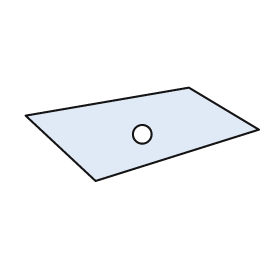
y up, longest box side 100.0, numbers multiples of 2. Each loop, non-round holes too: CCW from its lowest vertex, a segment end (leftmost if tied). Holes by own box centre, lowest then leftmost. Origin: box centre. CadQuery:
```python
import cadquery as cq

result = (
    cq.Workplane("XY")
    .moveTo(-20.0, -20.0)
    .lineTo(50.0, 2.0)
    .lineTo(20.0, 20.0)
    .lineTo(-50.0, 8.0)
    .close()
    .moveTo(0.0, 0.0)
    .circle(4.0)
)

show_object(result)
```